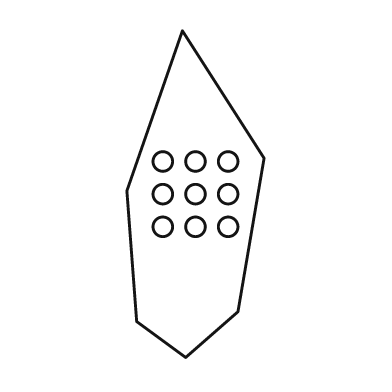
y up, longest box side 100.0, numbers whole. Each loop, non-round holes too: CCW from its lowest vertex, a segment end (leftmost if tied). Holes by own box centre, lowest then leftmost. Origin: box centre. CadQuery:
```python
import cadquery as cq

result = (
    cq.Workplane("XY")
    .moveTo(-3.0, -50.0)
    .lineTo(13.0, -36.0)
    .lineTo(21.0, 11.0)
    .lineTo(-4.0, 50.0)
    .lineTo(-21.0, 1.0)
    .lineTo(-18.0, -39.0)
    .close()
    .moveTo(-10.0, -10.0)
    .circle(3.0)
    .moveTo(0.0, -10.0)
    .circle(3.0)
    .moveTo(10.0, -10.0)
    .circle(3.0)
    .moveTo(-10.0, 0.0)
    .circle(3.0)
    .moveTo(0.0, 0.0)
    .circle(3.0)
    .moveTo(10.0, 0.0)
    .circle(3.0)
    .moveTo(-10.0, 10.0)
    .circle(3.0)
    .moveTo(0.0, 10.0)
    .circle(3.0)
    .moveTo(10.0, 10.0)
    .circle(3.0)
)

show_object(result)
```